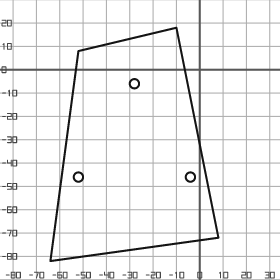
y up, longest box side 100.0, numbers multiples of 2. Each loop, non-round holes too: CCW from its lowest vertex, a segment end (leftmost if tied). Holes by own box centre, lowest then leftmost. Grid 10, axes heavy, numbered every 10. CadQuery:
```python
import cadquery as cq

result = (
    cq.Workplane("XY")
    .moveTo(-64.0, -82.0)
    .lineTo(8.0, -72.0)
    .lineTo(-10.0, 18.0)
    .lineTo(-52.0, 8.0)
    .close()
    .moveTo(-52.0, -46.0)
    .circle(2.0)
    .moveTo(-4.0, -46.0)
    .circle(2.0)
    .moveTo(-28.0, -6.0)
    .circle(2.0)
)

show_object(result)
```